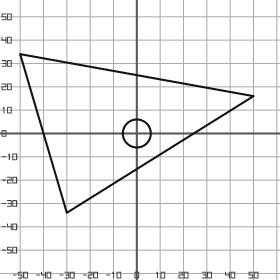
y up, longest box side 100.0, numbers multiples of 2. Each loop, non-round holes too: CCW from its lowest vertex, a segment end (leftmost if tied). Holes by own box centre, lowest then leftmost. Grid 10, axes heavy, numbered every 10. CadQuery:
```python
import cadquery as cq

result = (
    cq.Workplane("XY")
    .moveTo(-30.0, -34.0)
    .lineTo(50.0, 16.0)
    .lineTo(-50.0, 34.0)
    .close()
    .moveTo(0.0, 0.0)
    .circle(6.0)
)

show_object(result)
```